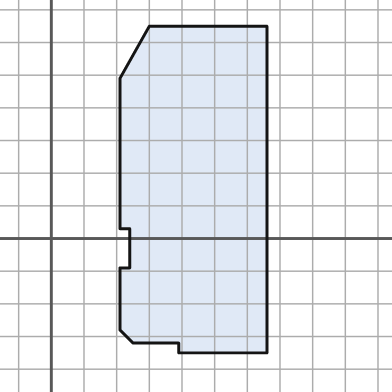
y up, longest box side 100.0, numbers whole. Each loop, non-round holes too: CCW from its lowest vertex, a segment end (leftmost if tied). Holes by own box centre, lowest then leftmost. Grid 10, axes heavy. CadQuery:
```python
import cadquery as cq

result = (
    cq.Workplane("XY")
    .moveTo(39.0, -35.0)
    .lineTo(66.0, -35.0)
    .lineTo(66.0, 65.0)
    .lineTo(30.0, 65.0)
    .lineTo(21.0, 49.0)
    .lineTo(21.0, 3.0)
    .lineTo(24.0, 3.0)
    .lineTo(24.0, -9.0)
    .lineTo(21.0, -9.0)
    .lineTo(21.0, -28.0)
    .lineTo(25.0, -32.0)
    .lineTo(39.0, -32.0)
    .close()
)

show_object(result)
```